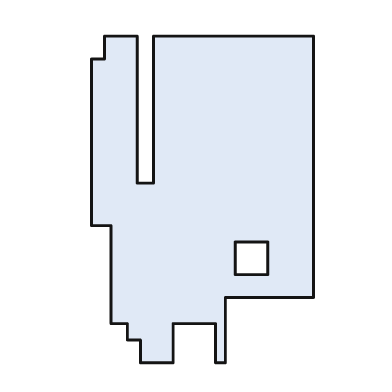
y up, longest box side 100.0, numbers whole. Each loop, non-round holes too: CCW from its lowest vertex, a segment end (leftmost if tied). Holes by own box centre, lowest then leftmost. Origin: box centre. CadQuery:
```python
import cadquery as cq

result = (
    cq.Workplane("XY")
    .moveTo(-19.0, -50.0)
    .lineTo(-9.0, -50.0)
    .lineTo(-9.0, -38.0)
    .lineTo(4.0, -38.0)
    .lineTo(4.0, -50.0)
    .lineTo(7.0, -50.0)
    .lineTo(7.0, -30.0)
    .lineTo(34.0, -30.0)
    .lineTo(34.0, 50.0)
    .lineTo(-15.0, 50.0)
    .lineTo(-15.0, 5.0)
    .lineTo(-20.0, 5.0)
    .lineTo(-20.0, 50.0)
    .lineTo(-30.0, 50.0)
    .lineTo(-30.0, 43.0)
    .lineTo(-34.0, 43.0)
    .lineTo(-34.0, -8.0)
    .lineTo(-28.0, -8.0)
    .lineTo(-28.0, -38.0)
    .lineTo(-23.0, -38.0)
    .lineTo(-23.0, -43.0)
    .lineTo(-19.0, -43.0)
    .close()
    .moveTo(10.0, -23.0)
    .lineTo(20.0, -23.0)
    .lineTo(20.0, -13.0)
    .lineTo(10.0, -13.0)
    .close()
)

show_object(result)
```